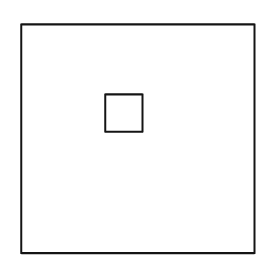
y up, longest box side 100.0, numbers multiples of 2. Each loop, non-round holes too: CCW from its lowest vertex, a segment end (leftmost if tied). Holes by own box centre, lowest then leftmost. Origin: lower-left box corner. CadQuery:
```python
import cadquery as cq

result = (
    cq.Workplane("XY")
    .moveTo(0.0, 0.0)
    .lineTo(100.0, 0.0)
    .lineTo(100.0, 98.0)
    .lineTo(0.0, 98.0)
    .close()
    .moveTo(36.0, 52.0)
    .lineTo(52.0, 52.0)
    .lineTo(52.0, 68.0)
    .lineTo(36.0, 68.0)
    .close()
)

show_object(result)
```